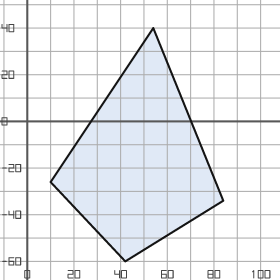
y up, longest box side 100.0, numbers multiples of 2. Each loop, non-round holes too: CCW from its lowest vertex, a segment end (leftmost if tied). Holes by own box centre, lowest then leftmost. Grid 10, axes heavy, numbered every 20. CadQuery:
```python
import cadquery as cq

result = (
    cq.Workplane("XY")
    .moveTo(42.0, -60.0)
    .lineTo(84.0, -34.0)
    .lineTo(54.0, 40.0)
    .lineTo(10.0, -26.0)
    .close()
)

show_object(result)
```